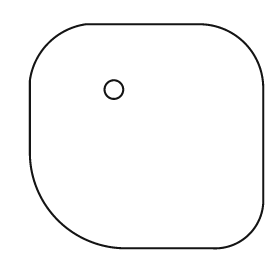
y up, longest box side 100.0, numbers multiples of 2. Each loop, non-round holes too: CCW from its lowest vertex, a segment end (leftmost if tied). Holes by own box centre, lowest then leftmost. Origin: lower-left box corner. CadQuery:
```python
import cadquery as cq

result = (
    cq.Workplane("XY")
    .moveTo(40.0, 0.0)
    .lineTo(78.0, 0.0)
    .threePointArc((94.0, 6.0), (100.0, 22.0))
    .lineTo(100.0, 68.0)
    .threePointArc((92.0, 88.0), (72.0, 96.0))
    .lineTo(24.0, 96.0)
    .threePointArc((8.0, 88.0), (0.0, 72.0))
    .lineTo(0.0, 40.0)
    .threePointArc((12.0, 12.0), (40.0, 0.0))
    .close()
    .moveTo(36.0, 68.0)
    .circle(4.0)
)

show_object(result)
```